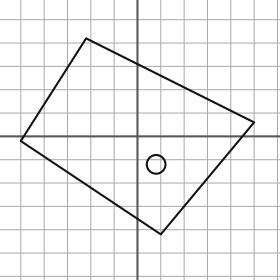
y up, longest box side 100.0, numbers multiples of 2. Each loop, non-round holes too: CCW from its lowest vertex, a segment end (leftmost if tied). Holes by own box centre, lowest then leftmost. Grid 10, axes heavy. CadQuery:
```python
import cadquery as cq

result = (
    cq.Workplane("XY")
    .moveTo(10.0, -42.0)
    .lineTo(50.0, 6.0)
    .lineTo(-22.0, 42.0)
    .lineTo(-50.0, -2.0)
    .close()
    .moveTo(8.0, -12.0)
    .circle(4.0)
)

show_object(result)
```